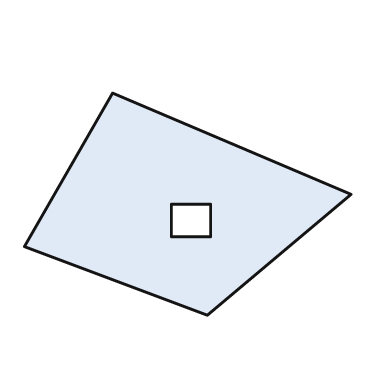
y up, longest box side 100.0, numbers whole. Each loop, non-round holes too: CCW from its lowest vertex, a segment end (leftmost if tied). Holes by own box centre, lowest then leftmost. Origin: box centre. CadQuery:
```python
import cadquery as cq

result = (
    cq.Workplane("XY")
    .moveTo(6.0, -34.0)
    .lineTo(50.0, 3.0)
    .lineTo(-23.0, 34.0)
    .lineTo(-50.0, -13.0)
    .close()
    .moveTo(-5.0, -10.0)
    .lineTo(7.0, -10.0)
    .lineTo(7.0, 0.0)
    .lineTo(-5.0, 0.0)
    .close()
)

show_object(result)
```